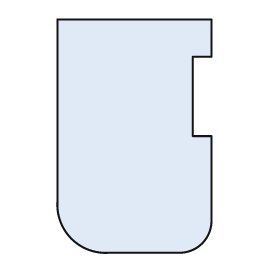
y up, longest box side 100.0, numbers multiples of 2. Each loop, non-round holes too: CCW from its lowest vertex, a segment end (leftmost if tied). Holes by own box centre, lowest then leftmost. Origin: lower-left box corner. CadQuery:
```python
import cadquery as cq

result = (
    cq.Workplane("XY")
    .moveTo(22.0, 0.0)
    .lineTo(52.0, 0.0)
    .threePointArc((62.0, 4.0), (66.0, 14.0))
    .lineTo(66.0, 50.0)
    .lineTo(58.0, 50.0)
    .lineTo(58.0, 84.0)
    .lineTo(66.0, 84.0)
    .lineTo(66.0, 100.0)
    .lineTo(0.0, 100.0)
    .lineTo(0.0, 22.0)
    .threePointArc((6.0, 6.0), (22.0, 0.0))
    .close()
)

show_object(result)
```